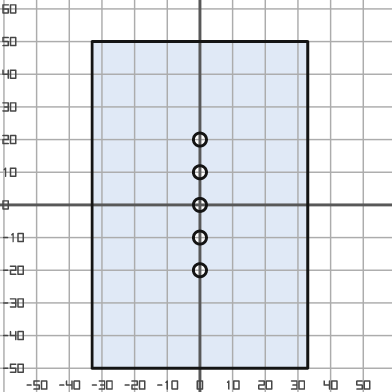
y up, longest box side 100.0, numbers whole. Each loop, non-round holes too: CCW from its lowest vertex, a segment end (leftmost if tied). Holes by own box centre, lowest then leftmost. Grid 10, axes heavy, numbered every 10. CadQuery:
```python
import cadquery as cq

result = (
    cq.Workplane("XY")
    .moveTo(-33.0, -50.0)
    .lineTo(33.0, -50.0)
    .lineTo(33.0, 50.0)
    .lineTo(-33.0, 50.0)
    .close()
    .moveTo(0.0, -20.0)
    .circle(2.0)
    .moveTo(0.0, -10.0)
    .circle(2.0)
    .moveTo(0.0, 0.0)
    .circle(2.0)
    .moveTo(0.0, 10.0)
    .circle(2.0)
    .moveTo(0.0, 20.0)
    .circle(2.0)
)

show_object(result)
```